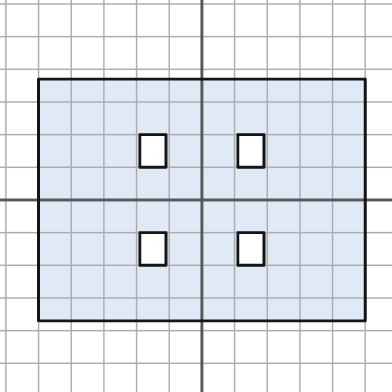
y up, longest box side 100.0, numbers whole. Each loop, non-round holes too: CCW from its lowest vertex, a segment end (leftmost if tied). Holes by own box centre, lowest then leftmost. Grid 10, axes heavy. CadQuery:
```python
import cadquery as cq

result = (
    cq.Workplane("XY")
    .moveTo(-50.0, -37.0)
    .lineTo(50.0, -37.0)
    .lineTo(50.0, 37.0)
    .lineTo(-50.0, 37.0)
    .close()
    .moveTo(-19.0, -20.0)
    .lineTo(-11.0, -20.0)
    .lineTo(-11.0, -10.0)
    .lineTo(-19.0, -10.0)
    .close()
    .moveTo(11.0, -20.0)
    .lineTo(19.0, -20.0)
    .lineTo(19.0, -10.0)
    .lineTo(11.0, -10.0)
    .close()
    .moveTo(-19.0, 10.0)
    .lineTo(-11.0, 10.0)
    .lineTo(-11.0, 20.0)
    .lineTo(-19.0, 20.0)
    .close()
    .moveTo(11.0, 10.0)
    .lineTo(19.0, 10.0)
    .lineTo(19.0, 20.0)
    .lineTo(11.0, 20.0)
    .close()
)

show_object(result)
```